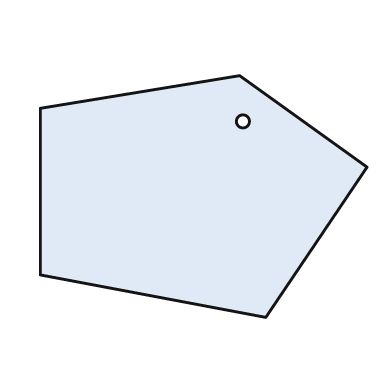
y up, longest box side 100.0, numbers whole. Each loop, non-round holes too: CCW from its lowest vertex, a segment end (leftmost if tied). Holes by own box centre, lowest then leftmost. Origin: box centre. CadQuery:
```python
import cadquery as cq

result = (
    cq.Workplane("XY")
    .moveTo(19.0, -37.0)
    .lineTo(50.0, 9.0)
    .lineTo(11.0, 37.0)
    .lineTo(-50.0, 27.0)
    .lineTo(-50.0, -24.0)
    .close()
    .moveTo(12.0, 23.0)
    .circle(2.0)
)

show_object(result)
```